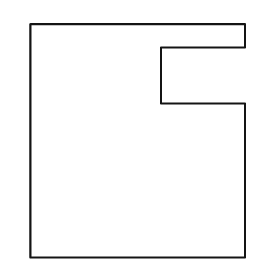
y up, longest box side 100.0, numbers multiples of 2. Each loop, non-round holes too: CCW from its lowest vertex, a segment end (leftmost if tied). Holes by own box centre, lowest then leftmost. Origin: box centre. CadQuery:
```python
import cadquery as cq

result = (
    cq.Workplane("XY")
    .moveTo(-46.0, -50.0)
    .lineTo(46.0, -50.0)
    .lineTo(46.0, 16.0)
    .lineTo(10.0, 16.0)
    .lineTo(10.0, 40.0)
    .lineTo(46.0, 40.0)
    .lineTo(46.0, 50.0)
    .lineTo(-46.0, 50.0)
    .close()
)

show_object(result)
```